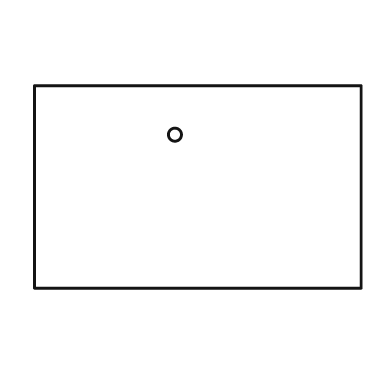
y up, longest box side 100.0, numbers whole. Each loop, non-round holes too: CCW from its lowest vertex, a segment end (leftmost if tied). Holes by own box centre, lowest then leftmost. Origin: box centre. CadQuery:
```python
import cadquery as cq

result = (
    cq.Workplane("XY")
    .moveTo(-50.0, -31.0)
    .lineTo(50.0, -31.0)
    .lineTo(50.0, 31.0)
    .lineTo(-50.0, 31.0)
    .close()
    .moveTo(-7.0, 16.0)
    .circle(2.0)
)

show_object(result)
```